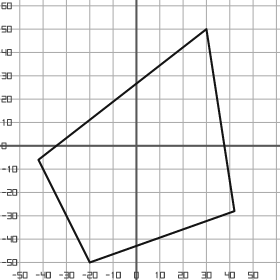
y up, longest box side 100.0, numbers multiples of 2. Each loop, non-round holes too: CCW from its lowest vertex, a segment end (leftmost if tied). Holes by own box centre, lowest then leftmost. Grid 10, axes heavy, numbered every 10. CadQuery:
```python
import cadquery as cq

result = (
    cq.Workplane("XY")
    .moveTo(-20.0, -50.0)
    .lineTo(42.0, -28.0)
    .lineTo(30.0, 50.0)
    .lineTo(-42.0, -6.0)
    .close()
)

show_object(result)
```